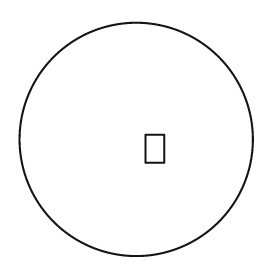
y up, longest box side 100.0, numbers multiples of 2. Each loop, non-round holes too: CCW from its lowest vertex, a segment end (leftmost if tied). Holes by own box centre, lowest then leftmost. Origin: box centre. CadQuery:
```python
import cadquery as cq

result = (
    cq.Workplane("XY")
    .moveTo(0.0, 0.0)
    .circle(50.0)
    .moveTo(4.0, -10.0)
    .lineTo(12.0, -10.0)
    .lineTo(12.0, 2.0)
    .lineTo(4.0, 2.0)
    .close()
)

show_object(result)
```